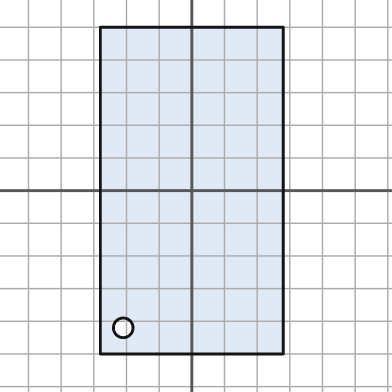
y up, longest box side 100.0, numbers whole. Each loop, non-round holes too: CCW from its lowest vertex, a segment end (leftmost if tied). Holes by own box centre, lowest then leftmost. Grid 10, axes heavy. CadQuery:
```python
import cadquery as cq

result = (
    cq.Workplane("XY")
    .moveTo(-28.0, -50.0)
    .lineTo(28.0, -50.0)
    .lineTo(28.0, 50.0)
    .lineTo(-28.0, 50.0)
    .close()
    .moveTo(-21.0, -42.0)
    .circle(3.0)
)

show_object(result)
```